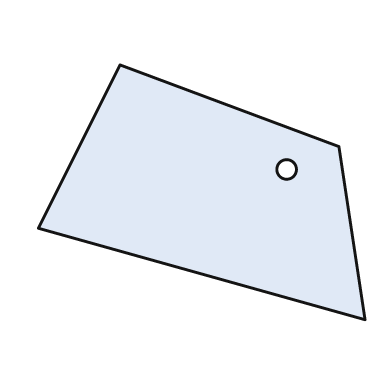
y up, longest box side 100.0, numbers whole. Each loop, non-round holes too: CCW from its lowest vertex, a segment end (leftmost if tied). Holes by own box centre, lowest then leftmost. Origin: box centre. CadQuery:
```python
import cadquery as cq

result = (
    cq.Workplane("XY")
    .moveTo(50.0, -39.0)
    .lineTo(42.0, 14.0)
    .lineTo(-25.0, 39.0)
    .lineTo(-50.0, -11.0)
    .close()
    .moveTo(26.0, 7.0)
    .circle(3.0)
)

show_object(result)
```